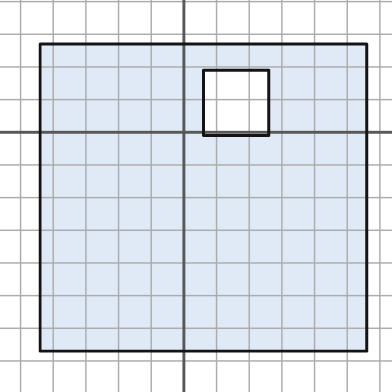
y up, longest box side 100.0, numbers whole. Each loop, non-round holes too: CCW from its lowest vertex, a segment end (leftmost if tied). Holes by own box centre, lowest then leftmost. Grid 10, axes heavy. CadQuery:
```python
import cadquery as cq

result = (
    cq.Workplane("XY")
    .moveTo(-44.0, -67.0)
    .lineTo(56.0, -67.0)
    .lineTo(56.0, 27.0)
    .lineTo(-44.0, 27.0)
    .close()
    .moveTo(6.0, -1.0)
    .lineTo(26.0, -1.0)
    .lineTo(26.0, 19.0)
    .lineTo(6.0, 19.0)
    .close()
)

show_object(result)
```